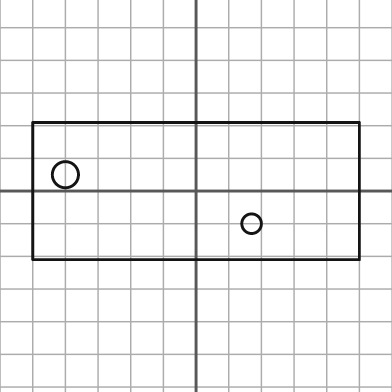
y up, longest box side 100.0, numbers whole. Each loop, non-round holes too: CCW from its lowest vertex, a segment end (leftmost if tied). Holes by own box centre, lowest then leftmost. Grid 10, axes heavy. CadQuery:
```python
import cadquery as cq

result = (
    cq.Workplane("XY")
    .moveTo(-50.0, -21.0)
    .lineTo(50.0, -21.0)
    .lineTo(50.0, 21.0)
    .lineTo(-50.0, 21.0)
    .close()
    .moveTo(17.0, -10.0)
    .circle(3.0)
    .moveTo(-40.0, 5.0)
    .circle(4.0)
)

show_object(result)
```